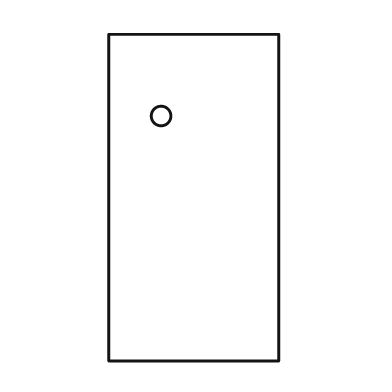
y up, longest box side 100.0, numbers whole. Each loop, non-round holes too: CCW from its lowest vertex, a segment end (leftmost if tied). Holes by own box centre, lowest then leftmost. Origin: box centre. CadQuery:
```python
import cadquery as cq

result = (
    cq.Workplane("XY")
    .moveTo(-26.0, -50.0)
    .lineTo(26.0, -50.0)
    .lineTo(26.0, 50.0)
    .lineTo(-26.0, 50.0)
    .close()
    .moveTo(-10.0, 25.0)
    .circle(3.0)
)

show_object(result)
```